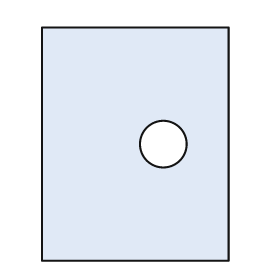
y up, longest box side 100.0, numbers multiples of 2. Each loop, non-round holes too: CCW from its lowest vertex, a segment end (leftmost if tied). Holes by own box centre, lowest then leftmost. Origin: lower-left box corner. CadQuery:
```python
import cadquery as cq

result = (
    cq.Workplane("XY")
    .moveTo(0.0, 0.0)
    .lineTo(80.0, 0.0)
    .lineTo(80.0, 100.0)
    .lineTo(0.0, 100.0)
    .close()
    .moveTo(52.0, 50.0)
    .circle(10.0)
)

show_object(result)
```